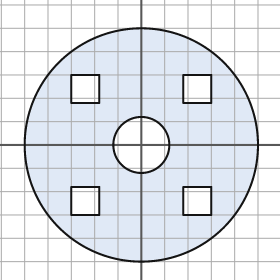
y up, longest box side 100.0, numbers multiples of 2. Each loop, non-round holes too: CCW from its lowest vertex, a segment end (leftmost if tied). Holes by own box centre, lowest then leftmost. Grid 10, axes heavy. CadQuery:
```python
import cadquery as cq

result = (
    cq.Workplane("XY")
    .moveTo(0.0, 0.0)
    .circle(50.0)
    .moveTo(-30.0, -30.0)
    .lineTo(-18.0, -30.0)
    .lineTo(-18.0, -18.0)
    .lineTo(-30.0, -18.0)
    .close()
    .moveTo(18.0, -30.0)
    .lineTo(30.0, -30.0)
    .lineTo(30.0, -18.0)
    .lineTo(18.0, -18.0)
    .close()
    .moveTo(0.0, 0.0)
    .circle(12.0)
    .moveTo(-30.0, 18.0)
    .lineTo(-18.0, 18.0)
    .lineTo(-18.0, 30.0)
    .lineTo(-30.0, 30.0)
    .close()
    .moveTo(18.0, 18.0)
    .lineTo(30.0, 18.0)
    .lineTo(30.0, 30.0)
    .lineTo(18.0, 30.0)
    .close()
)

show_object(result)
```